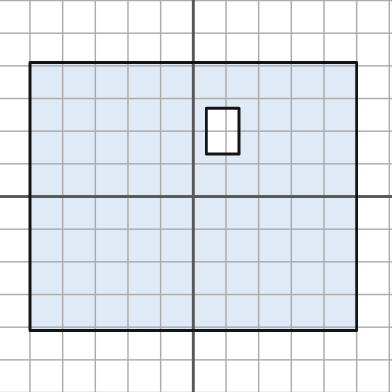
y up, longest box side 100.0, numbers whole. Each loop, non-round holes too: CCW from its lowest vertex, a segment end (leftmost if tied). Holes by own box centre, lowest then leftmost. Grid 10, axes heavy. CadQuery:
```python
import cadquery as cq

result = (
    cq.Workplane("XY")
    .moveTo(-50.0, -41.0)
    .lineTo(50.0, -41.0)
    .lineTo(50.0, 41.0)
    .lineTo(-50.0, 41.0)
    .close()
    .moveTo(4.0, 13.0)
    .lineTo(14.0, 13.0)
    .lineTo(14.0, 27.0)
    .lineTo(4.0, 27.0)
    .close()
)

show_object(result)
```